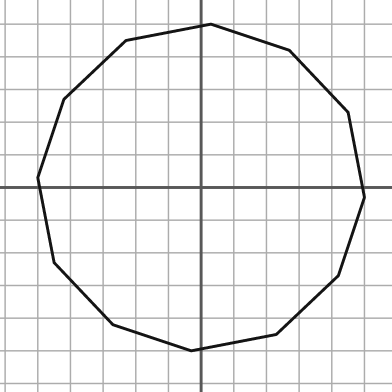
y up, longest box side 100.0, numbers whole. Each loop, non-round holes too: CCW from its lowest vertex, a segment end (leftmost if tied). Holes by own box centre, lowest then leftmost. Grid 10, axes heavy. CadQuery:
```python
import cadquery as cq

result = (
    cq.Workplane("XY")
    .moveTo(-3.0, -50.0)
    .lineTo(23.0, -45.0)
    .lineTo(42.0, -27.0)
    .lineTo(50.0, -3.0)
    .lineTo(45.0, 23.0)
    .lineTo(27.0, 42.0)
    .lineTo(3.0, 50.0)
    .lineTo(-23.0, 45.0)
    .lineTo(-42.0, 27.0)
    .lineTo(-50.0, 3.0)
    .lineTo(-45.0, -23.0)
    .lineTo(-27.0, -42.0)
    .close()
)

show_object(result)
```